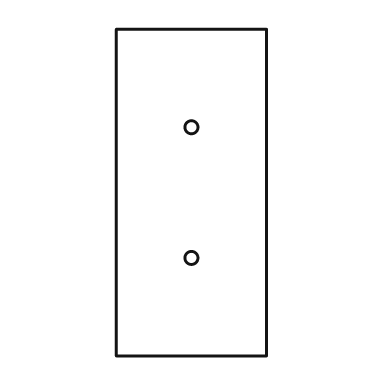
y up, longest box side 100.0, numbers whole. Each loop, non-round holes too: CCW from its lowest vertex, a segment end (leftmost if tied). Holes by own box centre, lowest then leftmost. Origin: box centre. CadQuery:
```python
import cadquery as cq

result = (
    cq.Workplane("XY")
    .moveTo(-23.0, -50.0)
    .lineTo(23.0, -50.0)
    .lineTo(23.0, 50.0)
    .lineTo(-23.0, 50.0)
    .close()
    .moveTo(0.0, -20.0)
    .circle(2.0)
    .moveTo(0.0, 20.0)
    .circle(2.0)
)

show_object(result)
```